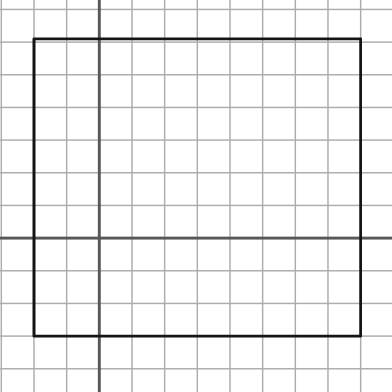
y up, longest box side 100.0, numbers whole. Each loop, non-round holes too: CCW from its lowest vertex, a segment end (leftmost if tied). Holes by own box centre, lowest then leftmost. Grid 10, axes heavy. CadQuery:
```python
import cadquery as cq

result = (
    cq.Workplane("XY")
    .moveTo(-20.0, -30.0)
    .lineTo(80.0, -30.0)
    .lineTo(80.0, 61.0)
    .lineTo(-20.0, 61.0)
    .close()
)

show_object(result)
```